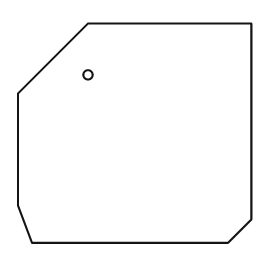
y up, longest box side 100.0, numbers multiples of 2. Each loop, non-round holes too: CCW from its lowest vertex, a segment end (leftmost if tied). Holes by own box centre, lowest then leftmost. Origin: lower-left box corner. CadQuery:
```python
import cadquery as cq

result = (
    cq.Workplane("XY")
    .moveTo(6.0, 0.0)
    .lineTo(90.0, 0.0)
    .lineTo(100.0, 10.0)
    .lineTo(100.0, 94.0)
    .lineTo(30.0, 94.0)
    .lineTo(0.0, 64.0)
    .lineTo(0.0, 16.0)
    .close()
    .moveTo(30.0, 72.0)
    .circle(2.0)
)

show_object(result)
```